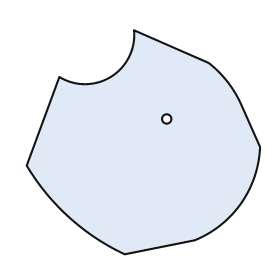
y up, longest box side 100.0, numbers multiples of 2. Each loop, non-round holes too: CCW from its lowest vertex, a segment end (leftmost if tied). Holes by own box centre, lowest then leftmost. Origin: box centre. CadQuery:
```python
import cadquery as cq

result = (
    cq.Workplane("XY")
    .moveTo(-8.0, -48.0)
    .lineTo(22.0, -42.0)
    .threePointArc((42.0, -26.0), (50.0, -2.0))
    .lineTo(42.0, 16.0)
    .threePointArc((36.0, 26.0), (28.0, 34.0))
    .lineTo(-4.0, 48.0)
    .threePointArc((-14.0, 28.0), (-36.0, 28.0))
    .lineTo(-50.0, -10.0)
    .threePointArc((-32.0, -32.0), (-8.0, -48.0))
    .close()
    .moveTo(10.0, 10.0)
    .circle(2.0)
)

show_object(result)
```